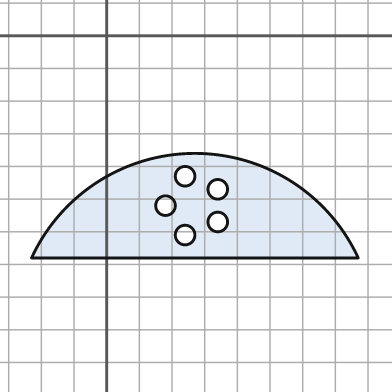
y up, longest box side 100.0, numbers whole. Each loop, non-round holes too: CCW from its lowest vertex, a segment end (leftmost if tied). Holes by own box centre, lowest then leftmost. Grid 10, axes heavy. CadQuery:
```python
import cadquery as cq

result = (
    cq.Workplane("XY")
    .moveTo(-23.0, -68.0)
    .lineTo(77.0, -68.0)
    .threePointArc((27.0, -36.0), (-23.0, -68.0))
    .close()
    .moveTo(24.0, -61.0)
    .circle(3.0)
    .moveTo(34.0, -57.0)
    .circle(3.0)
    .moveTo(18.0, -52.0)
    .circle(3.0)
    .moveTo(34.0, -47.0)
    .circle(3.0)
    .moveTo(24.0, -43.0)
    .circle(3.0)
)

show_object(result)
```